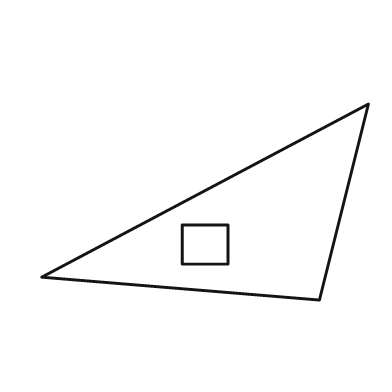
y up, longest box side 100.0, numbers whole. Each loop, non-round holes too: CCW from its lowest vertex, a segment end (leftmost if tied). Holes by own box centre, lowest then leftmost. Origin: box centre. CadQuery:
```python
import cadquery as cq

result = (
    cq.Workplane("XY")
    .moveTo(35.0, -30.0)
    .lineTo(50.0, 30.0)
    .lineTo(-50.0, -23.0)
    .close()
    .moveTo(-7.0, -19.0)
    .lineTo(7.0, -19.0)
    .lineTo(7.0, -7.0)
    .lineTo(-7.0, -7.0)
    .close()
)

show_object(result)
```